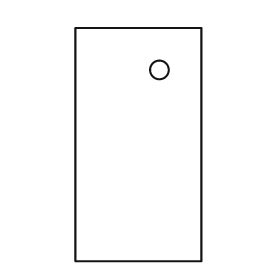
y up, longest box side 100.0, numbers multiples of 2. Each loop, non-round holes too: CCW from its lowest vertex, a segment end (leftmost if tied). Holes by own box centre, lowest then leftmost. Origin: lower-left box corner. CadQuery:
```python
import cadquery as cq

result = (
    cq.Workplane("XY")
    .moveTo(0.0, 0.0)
    .lineTo(54.0, 0.0)
    .lineTo(54.0, 100.0)
    .lineTo(0.0, 100.0)
    .close()
    .moveTo(36.0, 82.0)
    .circle(4.0)
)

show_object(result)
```